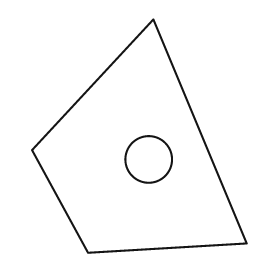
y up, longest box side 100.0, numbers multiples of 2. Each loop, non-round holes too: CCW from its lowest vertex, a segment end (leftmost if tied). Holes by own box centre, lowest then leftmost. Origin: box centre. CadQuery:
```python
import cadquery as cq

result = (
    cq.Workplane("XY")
    .moveTo(-22.0, -50.0)
    .lineTo(46.0, -46.0)
    .lineTo(6.0, 50.0)
    .lineTo(-46.0, -6.0)
    .close()
    .moveTo(4.0, -10.0)
    .circle(10.0)
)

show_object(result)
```